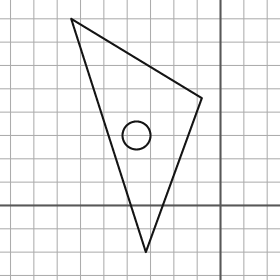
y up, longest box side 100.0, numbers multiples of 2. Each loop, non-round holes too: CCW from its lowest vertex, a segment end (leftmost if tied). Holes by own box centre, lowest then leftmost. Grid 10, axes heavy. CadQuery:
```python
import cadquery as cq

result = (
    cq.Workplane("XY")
    .moveTo(-32.0, -20.0)
    .lineTo(-8.0, 46.0)
    .lineTo(-64.0, 80.0)
    .close()
    .moveTo(-36.0, 30.0)
    .circle(6.0)
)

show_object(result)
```